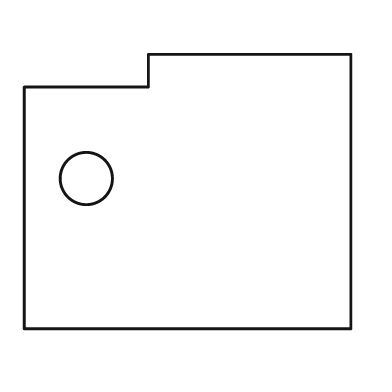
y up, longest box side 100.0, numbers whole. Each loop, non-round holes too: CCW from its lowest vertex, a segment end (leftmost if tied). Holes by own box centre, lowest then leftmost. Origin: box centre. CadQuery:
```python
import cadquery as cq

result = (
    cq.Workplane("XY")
    .moveTo(-50.0, -42.0)
    .lineTo(50.0, -42.0)
    .lineTo(50.0, 42.0)
    .lineTo(-12.0, 42.0)
    .lineTo(-12.0, 32.0)
    .lineTo(-50.0, 32.0)
    .close()
    .moveTo(-31.0, 4.0)
    .circle(8.0)
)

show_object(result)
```